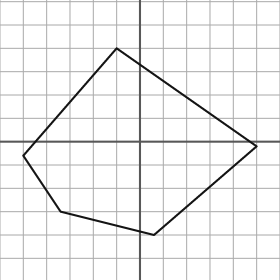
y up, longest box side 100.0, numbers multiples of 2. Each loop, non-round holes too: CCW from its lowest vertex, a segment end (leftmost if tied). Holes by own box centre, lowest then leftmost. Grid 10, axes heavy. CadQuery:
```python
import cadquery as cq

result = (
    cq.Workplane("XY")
    .moveTo(6.0, -40.0)
    .lineTo(50.0, -2.0)
    .lineTo(-10.0, 40.0)
    .lineTo(-50.0, -6.0)
    .lineTo(-34.0, -30.0)
    .close()
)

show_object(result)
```